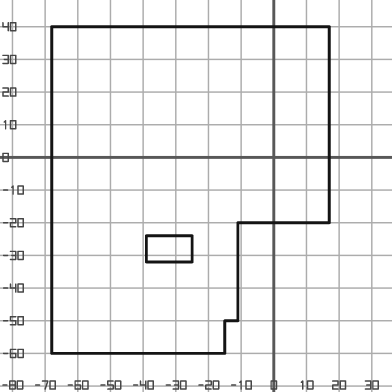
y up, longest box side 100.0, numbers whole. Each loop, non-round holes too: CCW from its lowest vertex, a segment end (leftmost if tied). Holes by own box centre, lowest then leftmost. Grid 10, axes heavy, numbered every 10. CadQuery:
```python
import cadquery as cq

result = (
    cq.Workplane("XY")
    .moveTo(-68.0, -60.0)
    .lineTo(-15.0, -60.0)
    .lineTo(-15.0, -50.0)
    .lineTo(-11.0, -50.0)
    .lineTo(-11.0, -20.0)
    .lineTo(17.0, -20.0)
    .lineTo(17.0, 40.0)
    .lineTo(-68.0, 40.0)
    .close()
    .moveTo(-39.0, -32.0)
    .lineTo(-25.0, -32.0)
    .lineTo(-25.0, -24.0)
    .lineTo(-39.0, -24.0)
    .close()
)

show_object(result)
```